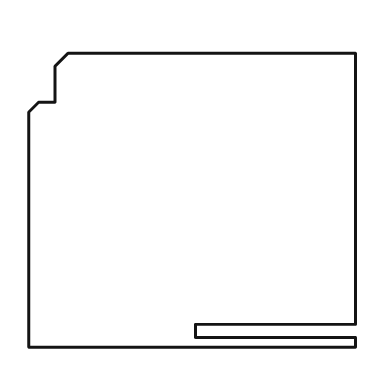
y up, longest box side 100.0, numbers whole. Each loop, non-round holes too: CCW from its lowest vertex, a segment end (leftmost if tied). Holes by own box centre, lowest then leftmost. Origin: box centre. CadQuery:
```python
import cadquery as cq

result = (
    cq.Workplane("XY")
    .moveTo(-50.0, -45.0)
    .lineTo(50.0, -45.0)
    .lineTo(50.0, -42.0)
    .lineTo(1.0, -42.0)
    .lineTo(1.0, -38.0)
    .lineTo(50.0, -38.0)
    .lineTo(50.0, 45.0)
    .lineTo(-38.0, 45.0)
    .lineTo(-42.0, 41.0)
    .lineTo(-42.0, 30.0)
    .lineTo(-47.0, 30.0)
    .lineTo(-50.0, 27.0)
    .close()
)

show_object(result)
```